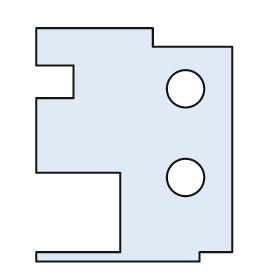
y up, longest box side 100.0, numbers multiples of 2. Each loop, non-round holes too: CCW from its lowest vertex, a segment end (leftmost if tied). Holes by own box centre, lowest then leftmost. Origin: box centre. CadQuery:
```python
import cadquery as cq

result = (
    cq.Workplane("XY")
    .moveTo(-42.0, -50.0)
    .lineTo(28.0, -50.0)
    .lineTo(28.0, -46.0)
    .lineTo(42.0, -46.0)
    .lineTo(42.0, 42.0)
    .lineTo(8.0, 42.0)
    .lineTo(8.0, 50.0)
    .lineTo(-42.0, 50.0)
    .lineTo(-42.0, 34.0)
    .lineTo(-26.0, 34.0)
    .lineTo(-26.0, 20.0)
    .lineTo(-42.0, 20.0)
    .lineTo(-42.0, -12.0)
    .lineTo(-6.0, -12.0)
    .lineTo(-6.0, -46.0)
    .lineTo(-42.0, -46.0)
    .close()
    .moveTo(22.0, -14.0)
    .circle(8.0)
    .moveTo(22.0, 24.0)
    .circle(8.0)
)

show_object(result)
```